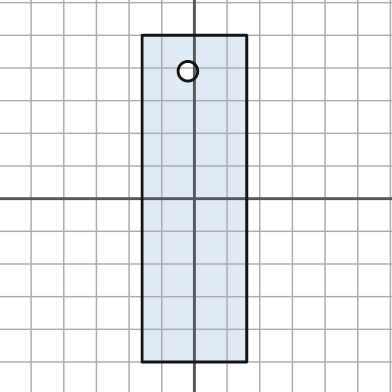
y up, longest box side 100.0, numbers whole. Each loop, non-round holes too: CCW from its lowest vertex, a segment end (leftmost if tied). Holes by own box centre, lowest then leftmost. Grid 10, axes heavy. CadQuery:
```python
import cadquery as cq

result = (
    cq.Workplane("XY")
    .moveTo(-16.0, -50.0)
    .lineTo(16.0, -50.0)
    .lineTo(16.0, 50.0)
    .lineTo(-16.0, 50.0)
    .close()
    .moveTo(-2.0, 39.0)
    .circle(3.0)
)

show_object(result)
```